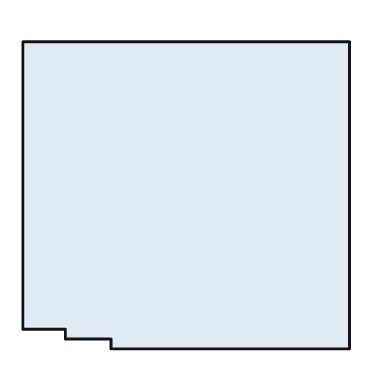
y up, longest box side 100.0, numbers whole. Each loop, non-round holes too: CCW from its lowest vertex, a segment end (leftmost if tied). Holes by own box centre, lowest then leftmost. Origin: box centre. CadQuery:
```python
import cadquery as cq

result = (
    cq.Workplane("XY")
    .moveTo(-23.0, -47.0)
    .lineTo(50.0, -47.0)
    .lineTo(50.0, 47.0)
    .lineTo(-50.0, 47.0)
    .lineTo(-50.0, -41.0)
    .lineTo(-37.0, -41.0)
    .lineTo(-37.0, -44.0)
    .lineTo(-23.0, -44.0)
    .close()
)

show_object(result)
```